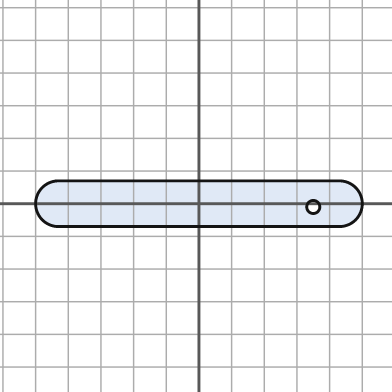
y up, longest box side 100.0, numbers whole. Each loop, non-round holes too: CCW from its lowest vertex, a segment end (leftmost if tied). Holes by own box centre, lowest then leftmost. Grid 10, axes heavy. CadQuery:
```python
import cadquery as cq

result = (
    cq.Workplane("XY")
    .moveTo(-43.0, -7.0)
    .lineTo(43.0, -7.0)
    .threePointArc((50.0, 0.0), (43.0, 7.0))
    .lineTo(-43.0, 7.0)
    .threePointArc((-50.0, 0.0), (-43.0, -7.0))
    .close()
    .moveTo(35.0, -1.0)
    .circle(2.0)
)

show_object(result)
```